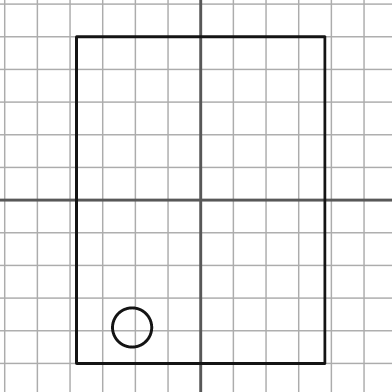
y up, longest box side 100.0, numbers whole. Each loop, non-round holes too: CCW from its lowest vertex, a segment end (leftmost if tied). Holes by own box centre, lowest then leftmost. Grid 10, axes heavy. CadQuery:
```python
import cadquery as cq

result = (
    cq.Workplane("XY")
    .moveTo(-38.0, -50.0)
    .lineTo(38.0, -50.0)
    .lineTo(38.0, 50.0)
    .lineTo(-38.0, 50.0)
    .close()
    .moveTo(-21.0, -39.0)
    .circle(6.0)
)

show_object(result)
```